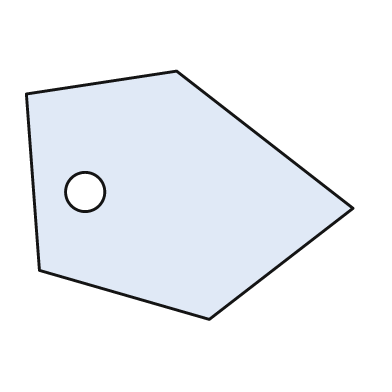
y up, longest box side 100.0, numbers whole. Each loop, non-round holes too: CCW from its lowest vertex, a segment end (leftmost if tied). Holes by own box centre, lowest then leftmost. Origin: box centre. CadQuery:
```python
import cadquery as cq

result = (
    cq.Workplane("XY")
    .moveTo(6.0, -38.0)
    .lineTo(50.0, -4.0)
    .lineTo(-4.0, 38.0)
    .lineTo(-50.0, 31.0)
    .lineTo(-46.0, -23.0)
    .close()
    .moveTo(-32.0, 1.0)
    .circle(6.0)
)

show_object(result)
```